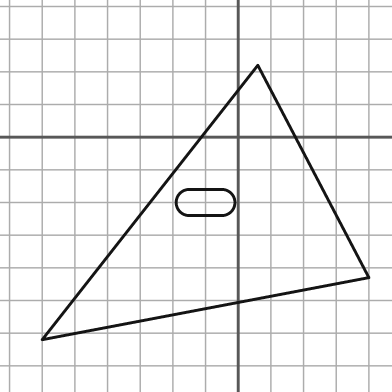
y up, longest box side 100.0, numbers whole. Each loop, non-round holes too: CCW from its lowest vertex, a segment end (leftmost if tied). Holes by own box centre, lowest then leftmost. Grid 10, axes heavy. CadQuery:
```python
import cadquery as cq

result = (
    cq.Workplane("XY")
    .moveTo(-60.0, -62.0)
    .lineTo(40.0, -43.0)
    .lineTo(6.0, 22.0)
    .close()
    .moveTo(-15.0, -24.0)
    .lineTo(-5.0, -24.0)
    .threePointArc((-1.0, -20.0), (-5.0, -16.0))
    .lineTo(-15.0, -16.0)
    .threePointArc((-19.0, -20.0), (-15.0, -24.0))
    .close()
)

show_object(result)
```